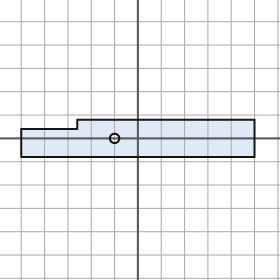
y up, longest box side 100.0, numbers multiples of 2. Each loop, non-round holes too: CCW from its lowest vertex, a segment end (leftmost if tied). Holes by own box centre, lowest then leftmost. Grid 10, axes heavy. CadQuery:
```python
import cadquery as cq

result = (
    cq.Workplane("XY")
    .moveTo(-50.0, -8.0)
    .lineTo(50.0, -8.0)
    .lineTo(50.0, 8.0)
    .lineTo(-26.0, 8.0)
    .lineTo(-26.0, 4.0)
    .lineTo(-50.0, 4.0)
    .close()
    .moveTo(-10.0, 0.0)
    .circle(2.0)
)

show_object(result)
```